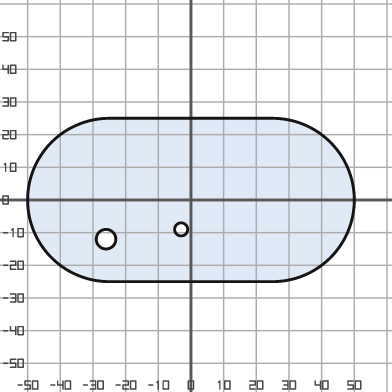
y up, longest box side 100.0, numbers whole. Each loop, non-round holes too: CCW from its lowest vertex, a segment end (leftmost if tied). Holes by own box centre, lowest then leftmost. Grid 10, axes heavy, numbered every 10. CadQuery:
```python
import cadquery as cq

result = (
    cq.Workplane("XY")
    .moveTo(-25.0, -25.0)
    .lineTo(25.0, -25.0)
    .threePointArc((50.0, 0.0), (25.0, 25.0))
    .lineTo(-25.0, 25.0)
    .threePointArc((-50.0, 0.0), (-25.0, -25.0))
    .close()
    .moveTo(-26.0, -12.0)
    .circle(3.0)
    .moveTo(-3.0, -9.0)
    .circle(2.0)
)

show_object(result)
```